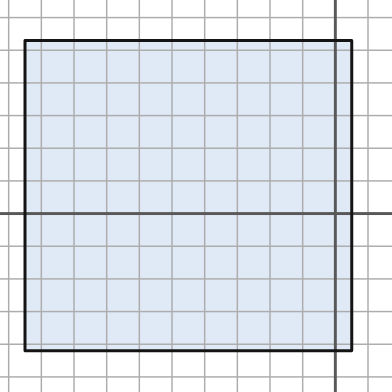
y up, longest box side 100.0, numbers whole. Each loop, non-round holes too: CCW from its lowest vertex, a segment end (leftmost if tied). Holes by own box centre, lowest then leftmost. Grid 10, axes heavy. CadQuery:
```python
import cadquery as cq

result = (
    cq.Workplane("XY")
    .moveTo(-95.0, -42.0)
    .lineTo(5.0, -42.0)
    .lineTo(5.0, 53.0)
    .lineTo(-95.0, 53.0)
    .close()
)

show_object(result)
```